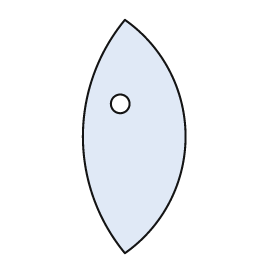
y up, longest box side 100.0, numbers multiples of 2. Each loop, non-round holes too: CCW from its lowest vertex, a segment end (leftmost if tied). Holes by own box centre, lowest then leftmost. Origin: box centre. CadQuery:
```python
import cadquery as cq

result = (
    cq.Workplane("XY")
    .moveTo(-4.0, -50.0)
    .threePointArc((22.0, 0.0), (-4.0, 50.0))
    .threePointArc((-22.0, 0.0), (-4.0, -50.0))
    .close()
    .moveTo(-6.0, 14.0)
    .circle(4.0)
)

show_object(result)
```